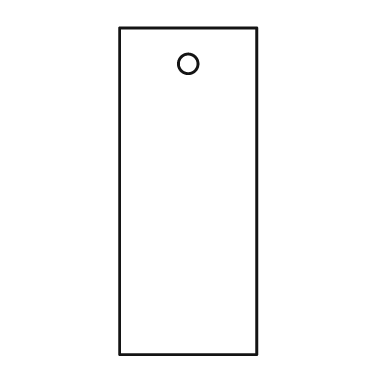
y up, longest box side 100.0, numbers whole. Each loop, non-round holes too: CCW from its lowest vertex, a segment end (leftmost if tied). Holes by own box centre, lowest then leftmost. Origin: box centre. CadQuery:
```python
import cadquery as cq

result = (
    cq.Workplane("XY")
    .moveTo(-21.0, -50.0)
    .lineTo(21.0, -50.0)
    .lineTo(21.0, 50.0)
    .lineTo(-21.0, 50.0)
    .close()
    .moveTo(0.0, 39.0)
    .circle(3.0)
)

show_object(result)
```